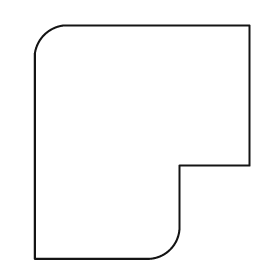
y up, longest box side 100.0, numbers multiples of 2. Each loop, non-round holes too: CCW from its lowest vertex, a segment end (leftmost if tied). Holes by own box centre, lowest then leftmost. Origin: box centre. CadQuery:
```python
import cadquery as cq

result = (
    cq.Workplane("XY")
    .moveTo(-46.0, -50.0)
    .lineTo(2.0, -50.0)
    .threePointArc((12.0, -46.0), (16.0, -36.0))
    .lineTo(16.0, -10.0)
    .lineTo(46.0, -10.0)
    .lineTo(46.0, 50.0)
    .lineTo(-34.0, 50.0)
    .threePointArc((-42.0, 46.0), (-46.0, 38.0))
    .close()
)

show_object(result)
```